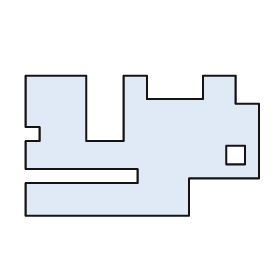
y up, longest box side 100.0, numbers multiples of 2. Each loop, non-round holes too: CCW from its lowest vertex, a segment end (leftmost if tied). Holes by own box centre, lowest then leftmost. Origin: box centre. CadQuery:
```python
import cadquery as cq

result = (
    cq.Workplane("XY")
    .moveTo(-50.0, -30.0)
    .lineTo(20.0, -30.0)
    .lineTo(20.0, -14.0)
    .lineTo(50.0, -14.0)
    .lineTo(50.0, 18.0)
    .lineTo(40.0, 18.0)
    .lineTo(40.0, 30.0)
    .lineTo(26.0, 30.0)
    .lineTo(26.0, 20.0)
    .lineTo(2.0, 20.0)
    .lineTo(2.0, 30.0)
    .lineTo(-8.0, 30.0)
    .lineTo(-8.0, 2.0)
    .lineTo(-24.0, 2.0)
    .lineTo(-24.0, 30.0)
    .lineTo(-50.0, 30.0)
    .lineTo(-50.0, 8.0)
    .lineTo(-44.0, 8.0)
    .lineTo(-44.0, 2.0)
    .lineTo(-50.0, 2.0)
    .lineTo(-50.0, -10.0)
    .lineTo(-2.0, -10.0)
    .lineTo(-2.0, -16.0)
    .lineTo(-50.0, -16.0)
    .close()
    .moveTo(36.0, -8.0)
    .lineTo(44.0, -8.0)
    .lineTo(44.0, 0.0)
    .lineTo(36.0, 0.0)
    .close()
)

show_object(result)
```